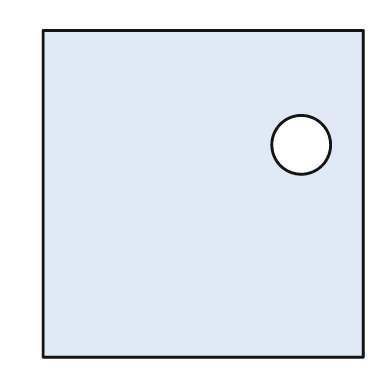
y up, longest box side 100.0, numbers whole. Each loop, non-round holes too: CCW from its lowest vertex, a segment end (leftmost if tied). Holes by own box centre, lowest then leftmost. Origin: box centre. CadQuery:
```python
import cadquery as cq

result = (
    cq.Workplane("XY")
    .moveTo(-49.0, -50.0)
    .lineTo(49.0, -50.0)
    .lineTo(49.0, 50.0)
    .lineTo(-49.0, 50.0)
    .close()
    .moveTo(30.0, 15.0)
    .circle(9.0)
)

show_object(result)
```